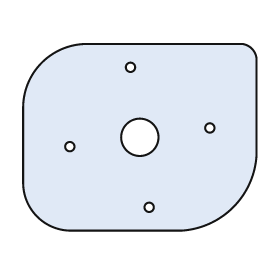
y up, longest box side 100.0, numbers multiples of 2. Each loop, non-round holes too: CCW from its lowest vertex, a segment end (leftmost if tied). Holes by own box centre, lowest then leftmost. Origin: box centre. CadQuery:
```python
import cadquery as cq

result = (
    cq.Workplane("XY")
    .moveTo(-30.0, -40.0)
    .lineTo(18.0, -40.0)
    .threePointArc((40.0, -30.0), (50.0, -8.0))
    .lineTo(50.0, 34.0)
    .threePointArc((48.0, 38.0), (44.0, 40.0))
    .lineTo(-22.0, 40.0)
    .threePointArc((-42.0, 32.0), (-50.0, 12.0))
    .lineTo(-50.0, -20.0)
    .threePointArc((-44.0, -34.0), (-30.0, -40.0))
    .close()
    .moveTo(4.0, -30.0)
    .circle(2.0)
    .moveTo(-30.0, -4.0)
    .circle(2.0)
    .moveTo(0.0, 0.0)
    .circle(8.0)
    .moveTo(30.0, 4.0)
    .circle(2.0)
    .moveTo(-4.0, 30.0)
    .circle(2.0)
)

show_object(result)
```